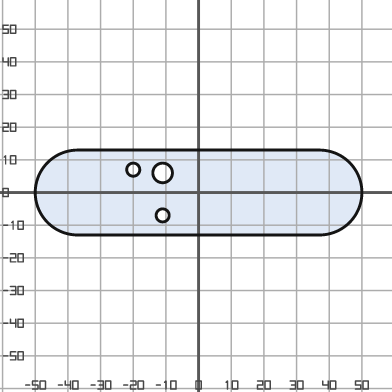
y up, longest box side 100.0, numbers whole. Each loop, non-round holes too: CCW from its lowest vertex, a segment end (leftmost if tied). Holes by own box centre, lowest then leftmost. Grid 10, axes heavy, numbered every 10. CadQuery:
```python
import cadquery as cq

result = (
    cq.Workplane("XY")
    .moveTo(-37.0, -13.0)
    .lineTo(37.0, -13.0)
    .threePointArc((50.0, 0.0), (37.0, 13.0))
    .lineTo(-37.0, 13.0)
    .threePointArc((-50.0, 0.0), (-37.0, -13.0))
    .close()
    .moveTo(-11.0, -7.0)
    .circle(2.0)
    .moveTo(-11.0, 6.0)
    .circle(3.0)
    .moveTo(-20.0, 7.0)
    .circle(2.0)
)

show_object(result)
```